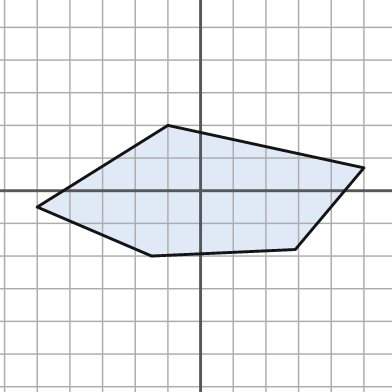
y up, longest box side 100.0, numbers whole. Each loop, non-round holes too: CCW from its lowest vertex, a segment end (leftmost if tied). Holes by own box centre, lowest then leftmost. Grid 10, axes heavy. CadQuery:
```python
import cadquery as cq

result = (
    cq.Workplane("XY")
    .moveTo(-15.0, -20.0)
    .lineTo(29.0, -18.0)
    .lineTo(50.0, 7.0)
    .lineTo(-10.0, 20.0)
    .lineTo(-50.0, -5.0)
    .close()
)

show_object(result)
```